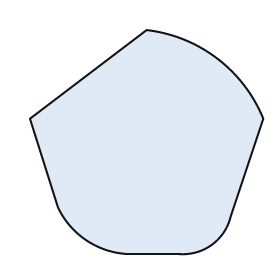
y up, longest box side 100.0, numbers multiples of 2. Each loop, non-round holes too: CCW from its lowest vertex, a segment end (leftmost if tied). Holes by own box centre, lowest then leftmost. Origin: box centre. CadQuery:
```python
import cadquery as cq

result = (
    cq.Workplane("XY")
    .moveTo(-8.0, -48.0)
    .lineTo(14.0, -48.0)
    .threePointArc((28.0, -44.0), (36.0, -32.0))
    .lineTo(50.0, 10.0)
    .threePointArc((30.0, 36.0), (0.0, 48.0))
    .lineTo(-50.0, 10.0)
    .lineTo(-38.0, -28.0)
    .threePointArc((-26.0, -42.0), (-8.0, -48.0))
    .close()
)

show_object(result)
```